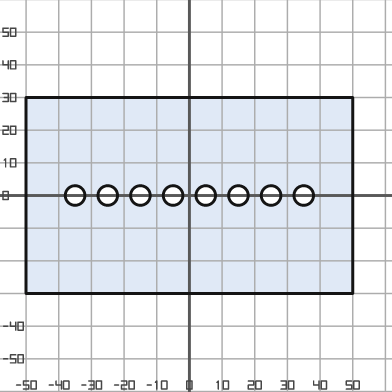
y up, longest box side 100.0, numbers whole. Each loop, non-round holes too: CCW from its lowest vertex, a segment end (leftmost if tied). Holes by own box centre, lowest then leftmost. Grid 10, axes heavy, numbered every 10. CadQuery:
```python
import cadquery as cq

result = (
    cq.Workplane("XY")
    .moveTo(-50.0, -30.0)
    .lineTo(50.0, -30.0)
    .lineTo(50.0, 30.0)
    .lineTo(-50.0, 30.0)
    .close()
    .moveTo(-35.0, 0.0)
    .circle(3.0)
    .moveTo(-25.0, 0.0)
    .circle(3.0)
    .moveTo(-15.0, 0.0)
    .circle(3.0)
    .moveTo(-5.0, 0.0)
    .circle(3.0)
    .moveTo(5.0, 0.0)
    .circle(3.0)
    .moveTo(15.0, 0.0)
    .circle(3.0)
    .moveTo(25.0, 0.0)
    .circle(3.0)
    .moveTo(35.0, 0.0)
    .circle(3.0)
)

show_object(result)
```